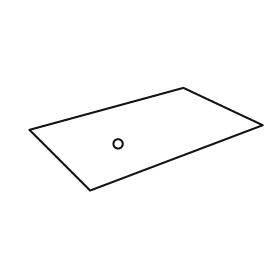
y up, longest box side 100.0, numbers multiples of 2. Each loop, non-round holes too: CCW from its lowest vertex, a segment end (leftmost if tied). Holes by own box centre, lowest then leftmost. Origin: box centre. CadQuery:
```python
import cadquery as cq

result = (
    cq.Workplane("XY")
    .moveTo(-24.0, -22.0)
    .lineTo(50.0, 6.0)
    .lineTo(16.0, 22.0)
    .lineTo(-50.0, 4.0)
    .close()
    .moveTo(-12.0, -2.0)
    .circle(2.0)
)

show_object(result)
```